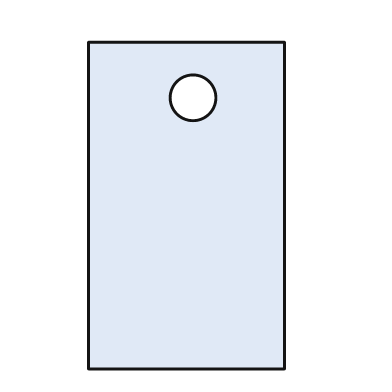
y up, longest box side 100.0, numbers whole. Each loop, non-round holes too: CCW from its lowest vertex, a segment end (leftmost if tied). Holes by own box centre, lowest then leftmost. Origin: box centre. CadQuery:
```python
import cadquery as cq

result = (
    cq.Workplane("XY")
    .moveTo(-30.0, -50.0)
    .lineTo(30.0, -50.0)
    .lineTo(30.0, 50.0)
    .lineTo(-30.0, 50.0)
    .close()
    .moveTo(2.0, 33.0)
    .circle(7.0)
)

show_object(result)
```